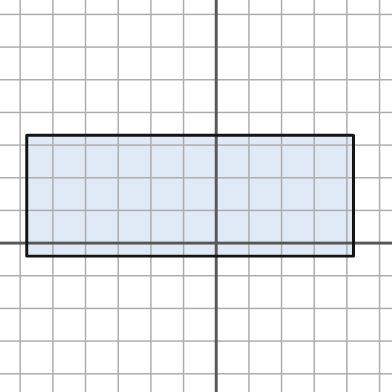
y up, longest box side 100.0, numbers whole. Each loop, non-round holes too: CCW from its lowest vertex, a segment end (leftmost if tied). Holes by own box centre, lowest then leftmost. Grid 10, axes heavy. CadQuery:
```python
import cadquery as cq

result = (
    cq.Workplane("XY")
    .moveTo(-58.0, -4.0)
    .lineTo(42.0, -4.0)
    .lineTo(42.0, 33.0)
    .lineTo(-58.0, 33.0)
    .close()
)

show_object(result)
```